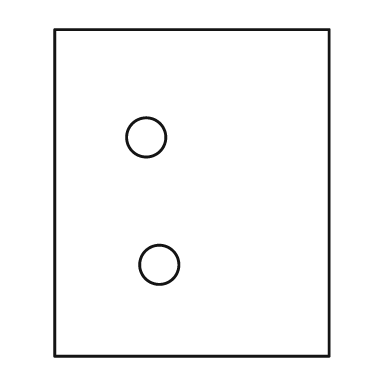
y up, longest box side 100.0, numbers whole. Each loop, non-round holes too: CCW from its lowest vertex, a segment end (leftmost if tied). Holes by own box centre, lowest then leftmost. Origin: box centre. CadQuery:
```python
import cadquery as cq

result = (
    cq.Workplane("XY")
    .moveTo(-42.0, -50.0)
    .lineTo(42.0, -50.0)
    .lineTo(42.0, 50.0)
    .lineTo(-42.0, 50.0)
    .close()
    .moveTo(-10.0, -22.0)
    .circle(6.0)
    .moveTo(-14.0, 17.0)
    .circle(6.0)
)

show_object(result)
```